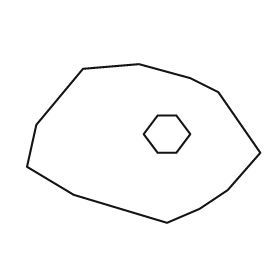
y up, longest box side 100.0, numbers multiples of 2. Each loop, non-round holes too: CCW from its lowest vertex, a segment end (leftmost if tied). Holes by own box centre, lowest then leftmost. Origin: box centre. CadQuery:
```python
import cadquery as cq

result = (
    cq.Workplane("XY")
    .moveTo(10.0, -34.0)
    .lineTo(24.0, -28.0)
    .lineTo(36.0, -20.0)
    .lineTo(50.0, -4.0)
    .lineTo(32.0, 22.0)
    .lineTo(20.0, 28.0)
    .lineTo(-2.0, 34.0)
    .lineTo(-26.0, 32.0)
    .lineTo(-46.0, 8.0)
    .lineTo(-50.0, -10.0)
    .lineTo(-30.0, -22.0)
    .close()
    .moveTo(6.0, -4.0)
    .lineTo(14.0, -4.0)
    .lineTo(20.0, 4.0)
    .lineTo(14.0, 12.0)
    .lineTo(6.0, 12.0)
    .lineTo(0.0, 4.0)
    .close()
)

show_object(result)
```